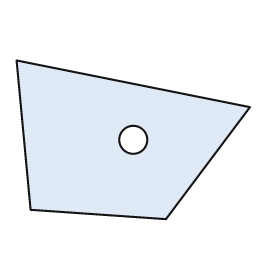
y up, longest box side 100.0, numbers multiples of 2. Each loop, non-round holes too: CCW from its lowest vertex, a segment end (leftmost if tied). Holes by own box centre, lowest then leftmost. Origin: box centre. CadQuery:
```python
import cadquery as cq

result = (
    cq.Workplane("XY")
    .moveTo(14.0, -34.0)
    .lineTo(50.0, 14.0)
    .lineTo(-50.0, 34.0)
    .lineTo(-44.0, -30.0)
    .close()
    .moveTo(0.0, 0.0)
    .circle(6.0)
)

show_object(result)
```